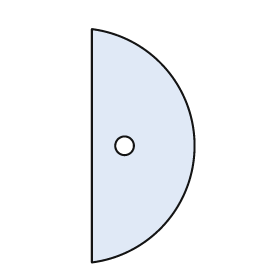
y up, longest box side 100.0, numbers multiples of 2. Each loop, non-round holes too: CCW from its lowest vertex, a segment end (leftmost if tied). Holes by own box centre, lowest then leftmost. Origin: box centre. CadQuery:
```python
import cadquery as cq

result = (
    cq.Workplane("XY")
    .moveTo(-22.0, -50.0)
    .threePointArc((22.0, 0.0), (-22.0, 50.0))
    .close()
    .moveTo(-8.0, 0.0)
    .circle(4.0)
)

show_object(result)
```